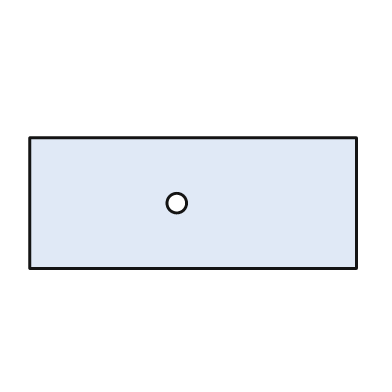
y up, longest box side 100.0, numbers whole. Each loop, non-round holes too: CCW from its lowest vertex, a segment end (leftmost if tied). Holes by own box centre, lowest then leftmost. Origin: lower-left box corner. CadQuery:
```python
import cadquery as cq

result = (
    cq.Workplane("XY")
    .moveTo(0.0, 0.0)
    .lineTo(100.0, 0.0)
    .lineTo(100.0, 40.0)
    .lineTo(0.0, 40.0)
    .close()
    .moveTo(45.0, 20.0)
    .circle(3.0)
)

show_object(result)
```